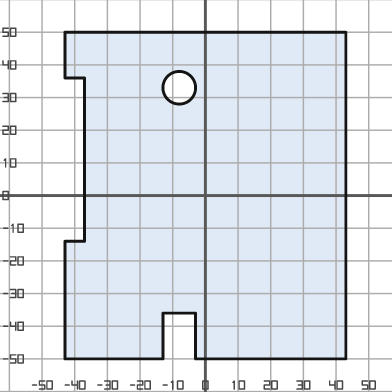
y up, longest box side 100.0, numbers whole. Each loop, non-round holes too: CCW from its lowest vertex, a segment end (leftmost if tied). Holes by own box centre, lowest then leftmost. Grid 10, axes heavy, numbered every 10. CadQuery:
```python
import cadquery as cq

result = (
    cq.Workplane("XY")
    .moveTo(-43.0, -50.0)
    .lineTo(-13.0, -50.0)
    .lineTo(-13.0, -36.0)
    .lineTo(-3.0, -36.0)
    .lineTo(-3.0, -50.0)
    .lineTo(43.0, -50.0)
    .lineTo(43.0, 50.0)
    .lineTo(-43.0, 50.0)
    .lineTo(-43.0, 36.0)
    .lineTo(-37.0, 36.0)
    .lineTo(-37.0, -14.0)
    .lineTo(-43.0, -14.0)
    .close()
    .moveTo(-8.0, 33.0)
    .circle(5.0)
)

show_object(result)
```